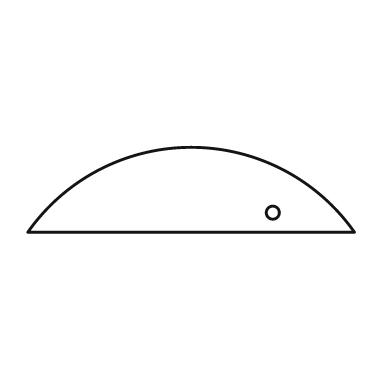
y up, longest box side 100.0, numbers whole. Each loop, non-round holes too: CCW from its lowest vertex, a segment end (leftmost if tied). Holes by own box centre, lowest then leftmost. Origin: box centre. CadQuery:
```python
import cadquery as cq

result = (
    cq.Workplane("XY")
    .moveTo(-50.0, -13.0)
    .lineTo(50.0, -13.0)
    .threePointArc((0.0, 13.0), (-50.0, -13.0))
    .close()
    .moveTo(25.0, -7.0)
    .circle(2.0)
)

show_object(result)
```